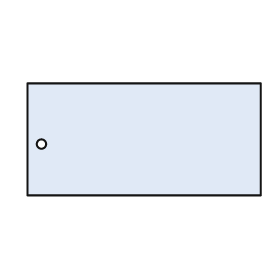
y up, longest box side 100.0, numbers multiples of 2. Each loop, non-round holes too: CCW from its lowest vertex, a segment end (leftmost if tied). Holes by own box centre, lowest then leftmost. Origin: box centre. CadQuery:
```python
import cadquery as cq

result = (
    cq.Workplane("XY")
    .moveTo(-50.0, -24.0)
    .lineTo(50.0, -24.0)
    .lineTo(50.0, 24.0)
    .lineTo(-50.0, 24.0)
    .close()
    .moveTo(-44.0, -2.0)
    .circle(2.0)
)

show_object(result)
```